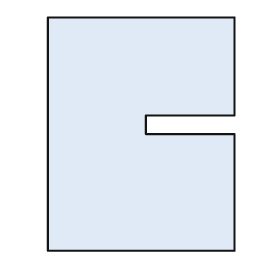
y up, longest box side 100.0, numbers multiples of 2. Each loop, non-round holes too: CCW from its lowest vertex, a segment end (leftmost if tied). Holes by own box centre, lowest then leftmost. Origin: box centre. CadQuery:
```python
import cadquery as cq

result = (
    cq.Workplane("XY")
    .moveTo(-40.0, -50.0)
    .lineTo(40.0, -50.0)
    .lineTo(40.0, 0.0)
    .lineTo(2.0, 0.0)
    .lineTo(2.0, 8.0)
    .lineTo(40.0, 8.0)
    .lineTo(40.0, 50.0)
    .lineTo(-40.0, 50.0)
    .close()
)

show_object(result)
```